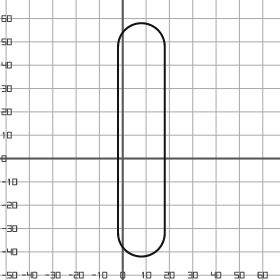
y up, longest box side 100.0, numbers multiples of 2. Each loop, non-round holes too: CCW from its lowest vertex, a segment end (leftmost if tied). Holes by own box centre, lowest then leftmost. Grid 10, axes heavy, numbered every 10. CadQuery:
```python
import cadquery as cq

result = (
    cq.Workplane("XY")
    .moveTo(-2.0, -32.0)
    .threePointArc((8.0, -42.0), (18.0, -32.0))
    .lineTo(18.0, 48.0)
    .threePointArc((8.0, 58.0), (-2.0, 48.0))
    .close()
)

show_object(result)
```